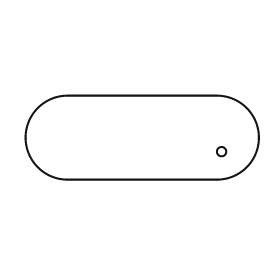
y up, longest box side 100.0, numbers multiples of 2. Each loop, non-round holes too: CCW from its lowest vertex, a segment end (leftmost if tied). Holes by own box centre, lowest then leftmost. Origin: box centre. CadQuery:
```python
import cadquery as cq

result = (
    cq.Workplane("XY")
    .moveTo(-32.0, -18.0)
    .lineTo(32.0, -18.0)
    .threePointArc((50.0, 0.0), (32.0, 18.0))
    .lineTo(-32.0, 18.0)
    .threePointArc((-50.0, 0.0), (-32.0, -18.0))
    .close()
    .moveTo(34.0, -6.0)
    .circle(2.0)
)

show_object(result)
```